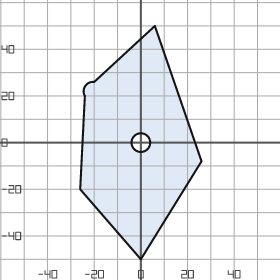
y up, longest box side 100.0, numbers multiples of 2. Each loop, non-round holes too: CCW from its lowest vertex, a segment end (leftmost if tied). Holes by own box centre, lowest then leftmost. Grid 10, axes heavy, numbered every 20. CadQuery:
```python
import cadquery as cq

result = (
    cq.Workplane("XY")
    .moveTo(0.0, -50.0)
    .lineTo(26.0, -8.0)
    .lineTo(6.0, 50.0)
    .lineTo(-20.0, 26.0)
    .threePointArc((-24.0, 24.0), (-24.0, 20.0))
    .lineTo(-26.0, -20.0)
    .close()
    .moveTo(0.0, 0.0)
    .circle(4.0)
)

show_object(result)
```